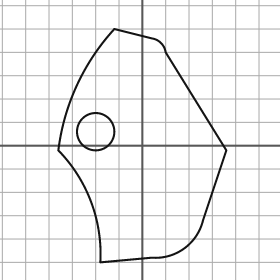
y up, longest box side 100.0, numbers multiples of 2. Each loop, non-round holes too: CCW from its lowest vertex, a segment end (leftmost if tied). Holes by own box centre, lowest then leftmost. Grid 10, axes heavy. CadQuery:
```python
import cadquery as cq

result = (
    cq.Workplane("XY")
    .moveTo(-18.0, -50.0)
    .lineTo(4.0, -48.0)
    .threePointArc((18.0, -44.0), (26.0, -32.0))
    .lineTo(36.0, -2.0)
    .lineTo(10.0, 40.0)
    .threePointArc((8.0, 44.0), (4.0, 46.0))
    .lineTo(-12.0, 50.0)
    .threePointArc((-28.0, 26.0), (-36.0, -2.0))
    .threePointArc((-22.0, -24.0), (-18.0, -50.0))
    .close()
    .moveTo(-20.0, 6.0)
    .circle(8.0)
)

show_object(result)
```